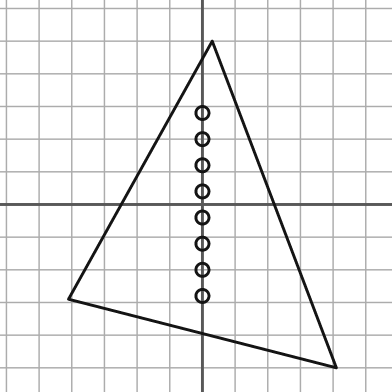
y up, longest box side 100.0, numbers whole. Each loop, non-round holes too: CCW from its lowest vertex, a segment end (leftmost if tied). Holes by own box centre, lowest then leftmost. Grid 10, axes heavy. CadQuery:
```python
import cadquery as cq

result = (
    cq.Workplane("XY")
    .moveTo(41.0, -50.0)
    .lineTo(3.0, 50.0)
    .lineTo(-41.0, -29.0)
    .close()
    .moveTo(0.0, -28.0)
    .circle(2.0)
    .moveTo(0.0, -20.0)
    .circle(2.0)
    .moveTo(0.0, -12.0)
    .circle(2.0)
    .moveTo(0.0, -4.0)
    .circle(2.0)
    .moveTo(0.0, 4.0)
    .circle(2.0)
    .moveTo(0.0, 12.0)
    .circle(2.0)
    .moveTo(0.0, 20.0)
    .circle(2.0)
    .moveTo(0.0, 28.0)
    .circle(2.0)
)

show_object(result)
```